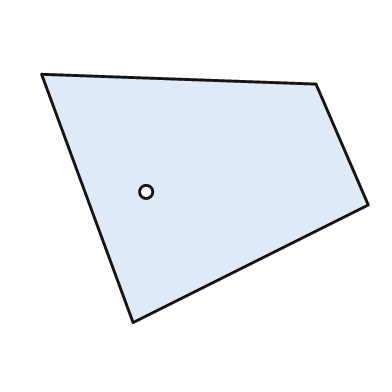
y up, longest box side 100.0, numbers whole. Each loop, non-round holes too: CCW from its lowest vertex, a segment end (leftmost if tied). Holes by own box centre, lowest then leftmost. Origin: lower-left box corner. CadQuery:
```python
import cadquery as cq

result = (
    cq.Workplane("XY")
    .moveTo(28.0, 0.0)
    .lineTo(100.0, 36.0)
    .lineTo(84.0, 73.0)
    .lineTo(0.0, 76.0)
    .close()
    .moveTo(32.0, 40.0)
    .circle(2.0)
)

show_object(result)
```